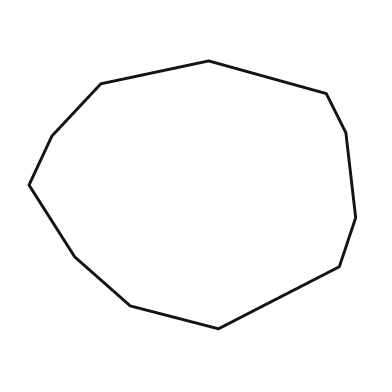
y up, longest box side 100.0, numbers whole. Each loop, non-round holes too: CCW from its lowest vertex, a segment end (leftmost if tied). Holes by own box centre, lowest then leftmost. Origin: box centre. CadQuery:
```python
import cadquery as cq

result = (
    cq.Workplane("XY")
    .moveTo(8.0, -41.0)
    .lineTo(45.0, -22.0)
    .lineTo(50.0, -7.0)
    .lineTo(47.0, 19.0)
    .lineTo(41.0, 31.0)
    .lineTo(5.0, 41.0)
    .lineTo(-28.0, 34.0)
    .lineTo(-43.0, 18.0)
    .lineTo(-50.0, 3.0)
    .lineTo(-36.0, -19.0)
    .lineTo(-19.0, -34.0)
    .close()
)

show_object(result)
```